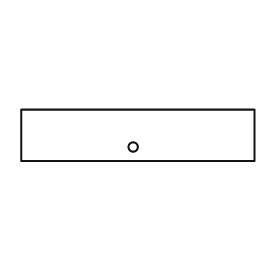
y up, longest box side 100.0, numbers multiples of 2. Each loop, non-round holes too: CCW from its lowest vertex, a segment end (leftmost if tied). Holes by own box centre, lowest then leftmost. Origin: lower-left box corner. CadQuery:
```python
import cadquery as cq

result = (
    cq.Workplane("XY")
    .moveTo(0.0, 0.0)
    .lineTo(100.0, 0.0)
    .lineTo(100.0, 22.0)
    .lineTo(0.0, 22.0)
    .close()
    .moveTo(48.0, 6.0)
    .circle(2.0)
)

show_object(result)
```